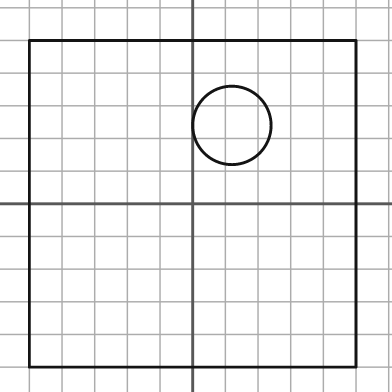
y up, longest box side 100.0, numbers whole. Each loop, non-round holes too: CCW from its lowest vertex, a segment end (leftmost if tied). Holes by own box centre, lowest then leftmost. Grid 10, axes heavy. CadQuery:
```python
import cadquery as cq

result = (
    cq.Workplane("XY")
    .moveTo(-50.0, -50.0)
    .lineTo(50.0, -50.0)
    .lineTo(50.0, 50.0)
    .lineTo(-50.0, 50.0)
    .close()
    .moveTo(12.0, 24.0)
    .circle(12.0)
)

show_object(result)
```